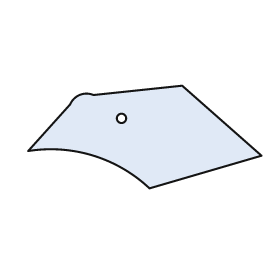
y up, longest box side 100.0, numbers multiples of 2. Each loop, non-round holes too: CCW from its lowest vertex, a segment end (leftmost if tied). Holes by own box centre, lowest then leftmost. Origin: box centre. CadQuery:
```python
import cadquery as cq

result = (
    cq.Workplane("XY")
    .moveTo(2.0, -22.0)
    .lineTo(50.0, -8.0)
    .lineTo(16.0, 22.0)
    .lineTo(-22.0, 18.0)
    .threePointArc((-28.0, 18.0), (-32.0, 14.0))
    .lineTo(-50.0, -6.0)
    .threePointArc((-22.0, -8.0), (2.0, -22.0))
    .close()
    .moveTo(-10.0, 8.0)
    .circle(2.0)
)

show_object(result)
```